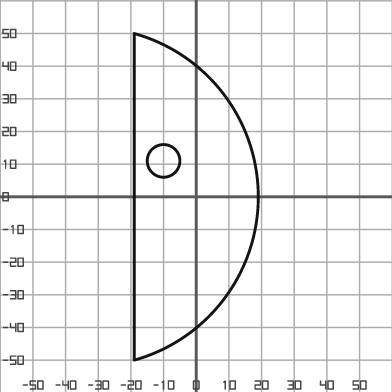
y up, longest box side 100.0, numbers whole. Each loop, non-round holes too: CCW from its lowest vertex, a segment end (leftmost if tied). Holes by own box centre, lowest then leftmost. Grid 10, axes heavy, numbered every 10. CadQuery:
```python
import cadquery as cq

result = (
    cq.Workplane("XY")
    .moveTo(-19.0, -50.0)
    .threePointArc((19.0, 0.0), (-19.0, 50.0))
    .close()
    .moveTo(-10.0, 11.0)
    .circle(5.0)
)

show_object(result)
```